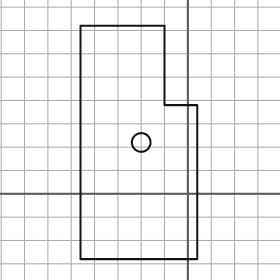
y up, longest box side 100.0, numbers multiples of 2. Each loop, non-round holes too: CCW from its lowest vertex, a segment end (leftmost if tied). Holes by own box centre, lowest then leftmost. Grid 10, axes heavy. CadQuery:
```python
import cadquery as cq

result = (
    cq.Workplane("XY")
    .moveTo(-46.0, -28.0)
    .lineTo(4.0, -28.0)
    .lineTo(4.0, 38.0)
    .lineTo(-10.0, 38.0)
    .lineTo(-10.0, 72.0)
    .lineTo(-46.0, 72.0)
    .close()
    .moveTo(-20.0, 22.0)
    .circle(4.0)
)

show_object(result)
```